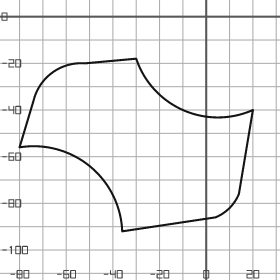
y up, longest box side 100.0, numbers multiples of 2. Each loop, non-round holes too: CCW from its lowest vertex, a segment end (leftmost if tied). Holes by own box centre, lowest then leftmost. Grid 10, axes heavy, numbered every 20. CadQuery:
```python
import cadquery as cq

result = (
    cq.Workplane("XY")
    .moveTo(-36.0, -92.0)
    .lineTo(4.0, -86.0)
    .threePointArc((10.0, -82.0), (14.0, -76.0))
    .lineTo(20.0, -40.0)
    .threePointArc((-10.0, -40.0), (-30.0, -18.0))
    .lineTo(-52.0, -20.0)
    .threePointArc((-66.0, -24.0), (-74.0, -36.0))
    .lineTo(-80.0, -56.0)
    .threePointArc((-50.0, -64.0), (-36.0, -92.0))
    .close()
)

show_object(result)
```